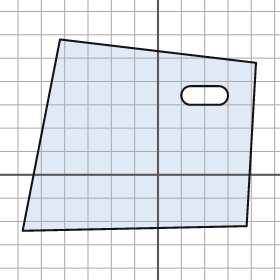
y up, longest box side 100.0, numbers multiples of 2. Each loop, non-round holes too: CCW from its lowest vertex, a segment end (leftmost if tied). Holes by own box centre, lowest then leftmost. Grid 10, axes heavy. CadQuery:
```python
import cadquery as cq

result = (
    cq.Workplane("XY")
    .moveTo(-58.0, -24.0)
    .lineTo(38.0, -22.0)
    .lineTo(42.0, 48.0)
    .lineTo(-42.0, 58.0)
    .close()
    .moveTo(14.0, 30.0)
    .lineTo(26.0, 30.0)
    .threePointArc((30.0, 34.0), (26.0, 38.0))
    .lineTo(14.0, 38.0)
    .threePointArc((10.0, 34.0), (14.0, 30.0))
    .close()
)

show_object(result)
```